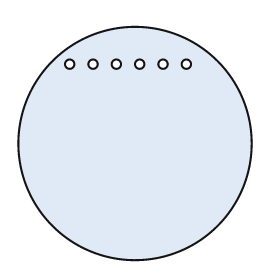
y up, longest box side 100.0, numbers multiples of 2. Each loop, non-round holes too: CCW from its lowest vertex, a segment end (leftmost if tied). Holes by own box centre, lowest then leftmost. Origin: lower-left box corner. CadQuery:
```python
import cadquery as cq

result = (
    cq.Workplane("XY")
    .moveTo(50.0, 50.0)
    .circle(50.0)
    .moveTo(22.0, 84.0)
    .circle(2.0)
    .moveTo(32.0, 84.0)
    .circle(2.0)
    .moveTo(42.0, 84.0)
    .circle(2.0)
    .moveTo(52.0, 84.0)
    .circle(2.0)
    .moveTo(62.0, 84.0)
    .circle(2.0)
    .moveTo(72.0, 84.0)
    .circle(2.0)
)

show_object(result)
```